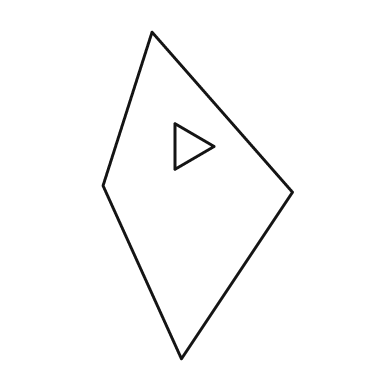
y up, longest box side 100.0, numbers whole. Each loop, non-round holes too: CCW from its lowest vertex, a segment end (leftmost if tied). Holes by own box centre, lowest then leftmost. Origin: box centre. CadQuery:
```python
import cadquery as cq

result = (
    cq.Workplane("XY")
    .moveTo(-5.0, -50.0)
    .lineTo(29.0, 1.0)
    .lineTo(-14.0, 50.0)
    .lineTo(-29.0, 3.0)
    .close()
    .moveTo(-7.0, 8.0)
    .lineTo(5.0, 15.0)
    .lineTo(-7.0, 22.0)
    .close()
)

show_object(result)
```